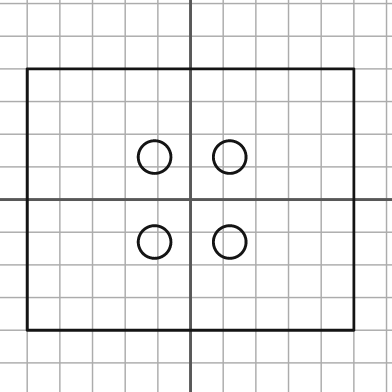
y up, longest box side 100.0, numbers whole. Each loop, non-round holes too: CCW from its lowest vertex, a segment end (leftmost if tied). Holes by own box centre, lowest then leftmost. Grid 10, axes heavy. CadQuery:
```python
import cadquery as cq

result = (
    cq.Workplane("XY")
    .moveTo(-50.0, -40.0)
    .lineTo(50.0, -40.0)
    .lineTo(50.0, 40.0)
    .lineTo(-50.0, 40.0)
    .close()
    .moveTo(-11.0, -13.0)
    .circle(5.0)
    .moveTo(12.0, -13.0)
    .circle(5.0)
    .moveTo(-11.0, 13.0)
    .circle(5.0)
    .moveTo(12.0, 13.0)
    .circle(5.0)
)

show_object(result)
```